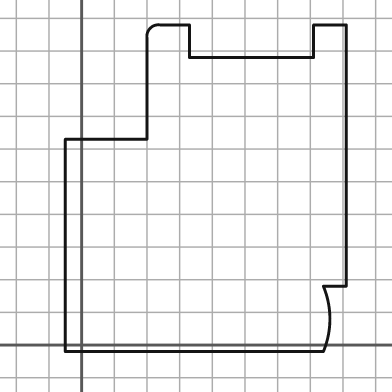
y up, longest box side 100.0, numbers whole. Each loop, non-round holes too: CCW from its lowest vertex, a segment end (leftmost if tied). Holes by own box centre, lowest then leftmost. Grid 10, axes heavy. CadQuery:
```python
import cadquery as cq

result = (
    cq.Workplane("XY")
    .moveTo(-5.0, -2.0)
    .lineTo(74.0, -2.0)
    .threePointArc((76.0, 8.0), (74.0, 18.0))
    .lineTo(81.0, 18.0)
    .lineTo(81.0, 98.0)
    .lineTo(71.0, 98.0)
    .lineTo(71.0, 88.0)
    .lineTo(33.0, 88.0)
    .lineTo(33.0, 98.0)
    .lineTo(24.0, 98.0)
    .threePointArc((21.0, 97.0), (20.0, 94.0))
    .lineTo(20.0, 63.0)
    .lineTo(-5.0, 63.0)
    .close()
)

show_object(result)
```